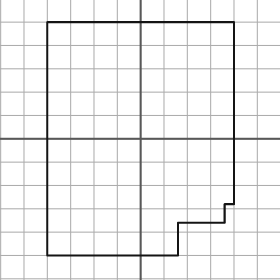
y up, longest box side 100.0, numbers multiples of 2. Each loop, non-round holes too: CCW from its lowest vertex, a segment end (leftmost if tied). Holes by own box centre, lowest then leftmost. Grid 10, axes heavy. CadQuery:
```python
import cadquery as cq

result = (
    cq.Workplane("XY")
    .moveTo(-40.0, -50.0)
    .lineTo(16.0, -50.0)
    .lineTo(16.0, -36.0)
    .lineTo(36.0, -36.0)
    .lineTo(36.0, -28.0)
    .lineTo(40.0, -28.0)
    .lineTo(40.0, 50.0)
    .lineTo(-40.0, 50.0)
    .close()
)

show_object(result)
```